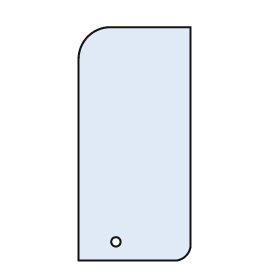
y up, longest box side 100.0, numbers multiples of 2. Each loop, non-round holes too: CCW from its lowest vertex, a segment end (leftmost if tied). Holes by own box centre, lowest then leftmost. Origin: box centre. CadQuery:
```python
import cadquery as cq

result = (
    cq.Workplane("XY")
    .moveTo(-24.0, -50.0)
    .lineTo(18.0, -50.0)
    .threePointArc((22.0, -48.0), (24.0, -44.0))
    .lineTo(24.0, 50.0)
    .lineTo(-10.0, 50.0)
    .threePointArc((-20.0, 46.0), (-24.0, 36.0))
    .close()
    .moveTo(-8.0, -42.0)
    .circle(2.0)
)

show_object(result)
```